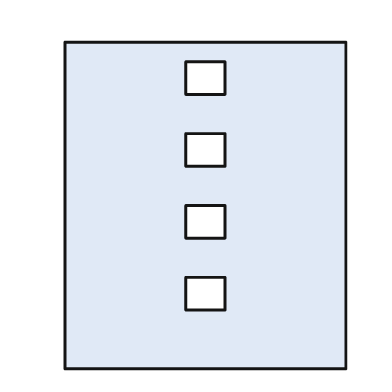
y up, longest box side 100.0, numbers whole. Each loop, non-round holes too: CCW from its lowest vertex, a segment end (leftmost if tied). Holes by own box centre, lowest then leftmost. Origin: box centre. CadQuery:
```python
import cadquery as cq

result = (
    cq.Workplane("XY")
    .moveTo(-43.0, -50.0)
    .lineTo(43.0, -50.0)
    .lineTo(43.0, 50.0)
    .lineTo(-43.0, 50.0)
    .close()
    .moveTo(-6.0, -32.0)
    .lineTo(6.0, -32.0)
    .lineTo(6.0, -22.0)
    .lineTo(-6.0, -22.0)
    .close()
    .moveTo(-6.0, -10.0)
    .lineTo(6.0, -10.0)
    .lineTo(6.0, 0.0)
    .lineTo(-6.0, 0.0)
    .close()
    .moveTo(-6.0, 12.0)
    .lineTo(6.0, 12.0)
    .lineTo(6.0, 22.0)
    .lineTo(-6.0, 22.0)
    .close()
    .moveTo(-6.0, 34.0)
    .lineTo(6.0, 34.0)
    .lineTo(6.0, 44.0)
    .lineTo(-6.0, 44.0)
    .close()
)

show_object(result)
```